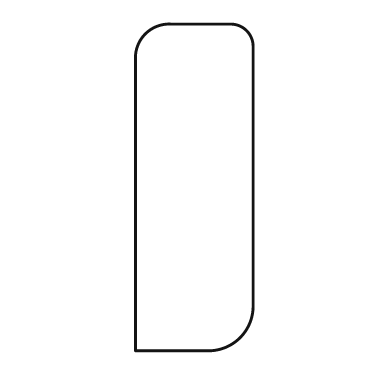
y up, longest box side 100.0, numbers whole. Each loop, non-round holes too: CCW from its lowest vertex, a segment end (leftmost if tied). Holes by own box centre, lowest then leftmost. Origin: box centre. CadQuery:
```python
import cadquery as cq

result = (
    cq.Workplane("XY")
    .moveTo(-18.0, -50.0)
    .lineTo(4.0, -50.0)
    .threePointArc((14.0, -46.0), (18.0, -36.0))
    .lineTo(18.0, 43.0)
    .threePointArc((16.0, 48.0), (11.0, 50.0))
    .lineTo(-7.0, 50.0)
    .threePointArc((-15.0, 47.0), (-18.0, 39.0))
    .close()
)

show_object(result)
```